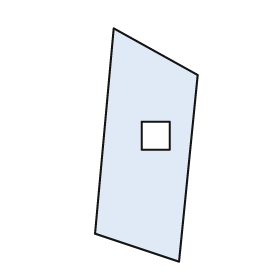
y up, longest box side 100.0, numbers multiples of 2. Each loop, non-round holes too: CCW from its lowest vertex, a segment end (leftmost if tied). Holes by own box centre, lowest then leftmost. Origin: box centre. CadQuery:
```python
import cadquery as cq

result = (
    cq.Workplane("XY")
    .moveTo(14.0, -50.0)
    .lineTo(22.0, 30.0)
    .lineTo(-14.0, 50.0)
    .lineTo(-22.0, -38.0)
    .close()
    .moveTo(-2.0, -2.0)
    .lineTo(10.0, -2.0)
    .lineTo(10.0, 10.0)
    .lineTo(-2.0, 10.0)
    .close()
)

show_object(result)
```